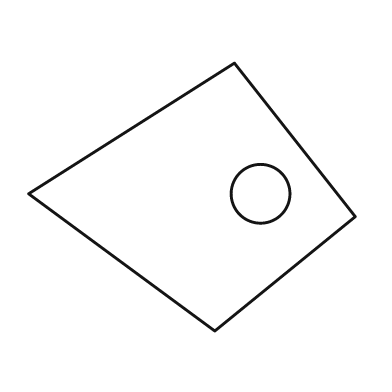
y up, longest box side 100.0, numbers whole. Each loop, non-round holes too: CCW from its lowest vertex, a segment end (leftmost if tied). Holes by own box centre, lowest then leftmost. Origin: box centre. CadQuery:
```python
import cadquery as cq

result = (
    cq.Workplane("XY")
    .moveTo(7.0, -41.0)
    .lineTo(50.0, -6.0)
    .lineTo(13.0, 41.0)
    .lineTo(-50.0, 1.0)
    .close()
    .moveTo(21.0, 1.0)
    .circle(9.0)
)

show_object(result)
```